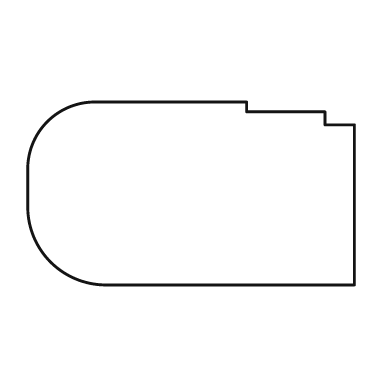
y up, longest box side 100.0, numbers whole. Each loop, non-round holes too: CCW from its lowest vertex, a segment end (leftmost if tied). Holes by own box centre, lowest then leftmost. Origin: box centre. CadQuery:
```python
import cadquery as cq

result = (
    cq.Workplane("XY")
    .moveTo(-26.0, -28.0)
    .lineTo(50.0, -28.0)
    .lineTo(50.0, 21.0)
    .lineTo(41.0, 21.0)
    .lineTo(41.0, 25.0)
    .lineTo(17.0, 25.0)
    .lineTo(17.0, 28.0)
    .lineTo(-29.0, 28.0)
    .threePointArc((-44.0, 22.0), (-50.0, 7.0))
    .lineTo(-50.0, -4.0)
    .threePointArc((-43.0, -21.0), (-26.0, -28.0))
    .close()
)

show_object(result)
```